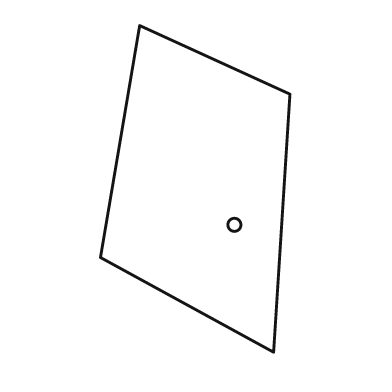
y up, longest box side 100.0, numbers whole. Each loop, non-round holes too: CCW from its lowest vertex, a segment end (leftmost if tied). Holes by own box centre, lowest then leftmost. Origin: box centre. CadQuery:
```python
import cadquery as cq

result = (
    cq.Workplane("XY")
    .moveTo(24.0, -50.0)
    .lineTo(29.0, 29.0)
    .lineTo(-17.0, 50.0)
    .lineTo(-29.0, -21.0)
    .close()
    .moveTo(12.0, -11.0)
    .circle(2.0)
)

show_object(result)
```